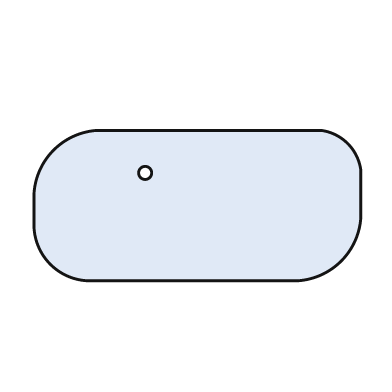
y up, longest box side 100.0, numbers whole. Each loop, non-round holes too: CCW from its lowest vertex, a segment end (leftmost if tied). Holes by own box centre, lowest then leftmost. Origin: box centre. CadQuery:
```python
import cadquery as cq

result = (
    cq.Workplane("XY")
    .moveTo(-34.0, -23.0)
    .lineTo(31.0, -23.0)
    .threePointArc((44.0, -17.0), (50.0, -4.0))
    .lineTo(50.0, 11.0)
    .threePointArc((46.0, 19.0), (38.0, 23.0))
    .lineTo(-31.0, 23.0)
    .threePointArc((-44.0, 17.0), (-50.0, 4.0))
    .lineTo(-50.0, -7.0)
    .threePointArc((-45.0, -18.0), (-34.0, -23.0))
    .close()
    .moveTo(-16.0, 10.0)
    .circle(2.0)
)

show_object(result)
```